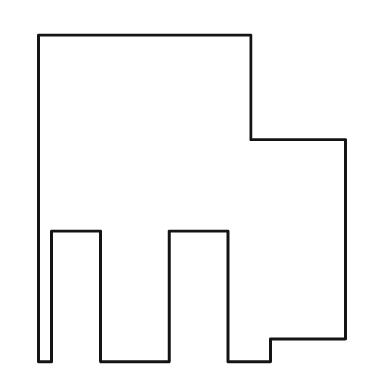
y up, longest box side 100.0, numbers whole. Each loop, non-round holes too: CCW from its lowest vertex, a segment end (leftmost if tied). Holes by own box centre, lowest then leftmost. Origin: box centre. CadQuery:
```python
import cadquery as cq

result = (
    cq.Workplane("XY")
    .moveTo(-47.0, -50.0)
    .lineTo(-43.0, -50.0)
    .lineTo(-43.0, -10.0)
    .lineTo(-28.0, -10.0)
    .lineTo(-28.0, -50.0)
    .lineTo(-7.0, -50.0)
    .lineTo(-7.0, -10.0)
    .lineTo(11.0, -10.0)
    .lineTo(11.0, -50.0)
    .lineTo(24.0, -50.0)
    .lineTo(24.0, -43.0)
    .lineTo(47.0, -43.0)
    .lineTo(47.0, 18.0)
    .lineTo(18.0, 18.0)
    .lineTo(18.0, 50.0)
    .lineTo(-47.0, 50.0)
    .close()
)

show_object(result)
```